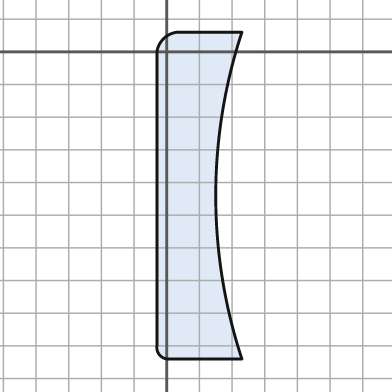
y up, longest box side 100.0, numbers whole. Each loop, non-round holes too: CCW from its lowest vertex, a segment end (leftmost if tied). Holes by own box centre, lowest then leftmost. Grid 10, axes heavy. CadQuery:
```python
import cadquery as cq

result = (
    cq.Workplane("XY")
    .moveTo(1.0, -94.0)
    .lineTo(23.0, -94.0)
    .threePointArc((15.0, -44.0), (23.0, 6.0))
    .lineTo(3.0, 6.0)
    .threePointArc((-1.0, 4.0), (-3.0, 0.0))
    .lineTo(-3.0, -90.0)
    .threePointArc((-2.0, -93.0), (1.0, -94.0))
    .close()
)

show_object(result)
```